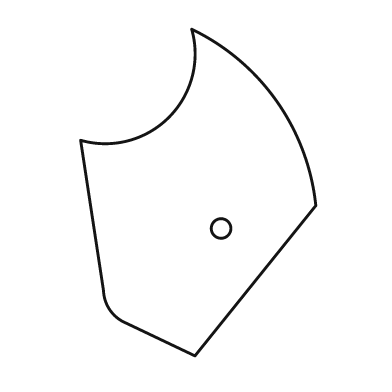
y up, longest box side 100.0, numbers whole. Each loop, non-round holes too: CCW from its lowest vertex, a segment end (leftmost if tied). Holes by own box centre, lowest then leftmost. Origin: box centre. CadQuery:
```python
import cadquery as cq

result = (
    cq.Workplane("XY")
    .moveTo(-1.0, -50.0)
    .lineTo(36.0, -4.0)
    .threePointArc((24.0, 28.0), (-2.0, 50.0))
    .threePointArc((-9.0, 23.0), (-36.0, 16.0))
    .lineTo(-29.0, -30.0)
    .threePointArc((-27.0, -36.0), (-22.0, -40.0))
    .close()
    .moveTo(7.0, -11.0)
    .circle(3.0)
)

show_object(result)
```